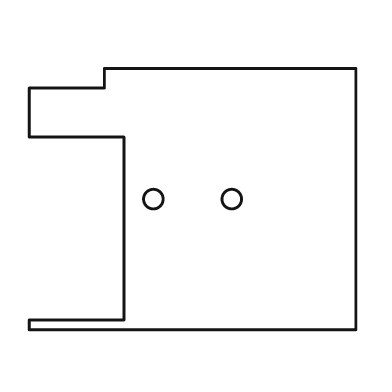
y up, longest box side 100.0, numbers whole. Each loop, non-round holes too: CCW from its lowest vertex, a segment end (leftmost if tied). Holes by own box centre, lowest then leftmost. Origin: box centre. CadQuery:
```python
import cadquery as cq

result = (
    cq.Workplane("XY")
    .moveTo(-50.0, -40.0)
    .lineTo(50.0, -40.0)
    .lineTo(50.0, 40.0)
    .lineTo(-27.0, 40.0)
    .lineTo(-27.0, 34.0)
    .lineTo(-50.0, 34.0)
    .lineTo(-50.0, 19.0)
    .lineTo(-21.0, 19.0)
    .lineTo(-21.0, -37.0)
    .lineTo(-50.0, -37.0)
    .close()
    .moveTo(-12.0, 0.0)
    .circle(3.0)
    .moveTo(12.0, 0.0)
    .circle(3.0)
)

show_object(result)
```